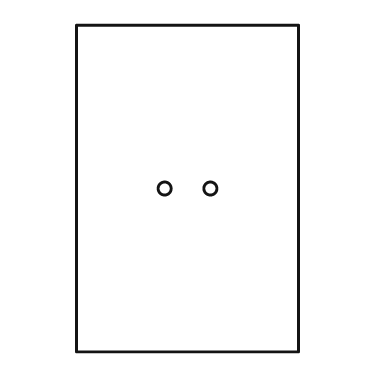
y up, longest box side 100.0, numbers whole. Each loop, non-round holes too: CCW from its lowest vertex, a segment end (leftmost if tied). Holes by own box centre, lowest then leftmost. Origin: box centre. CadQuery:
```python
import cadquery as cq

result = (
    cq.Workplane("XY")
    .moveTo(-34.0, -50.0)
    .lineTo(34.0, -50.0)
    .lineTo(34.0, 50.0)
    .lineTo(-34.0, 50.0)
    .close()
    .moveTo(-7.0, 0.0)
    .circle(2.0)
    .moveTo(7.0, 0.0)
    .circle(2.0)
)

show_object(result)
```